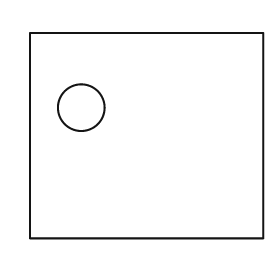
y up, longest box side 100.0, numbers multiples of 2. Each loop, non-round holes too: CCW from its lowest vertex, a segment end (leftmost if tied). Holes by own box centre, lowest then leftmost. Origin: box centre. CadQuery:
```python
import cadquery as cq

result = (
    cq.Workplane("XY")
    .moveTo(-50.0, -44.0)
    .lineTo(50.0, -44.0)
    .lineTo(50.0, 44.0)
    .lineTo(-50.0, 44.0)
    .close()
    .moveTo(-28.0, 12.0)
    .circle(10.0)
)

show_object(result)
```